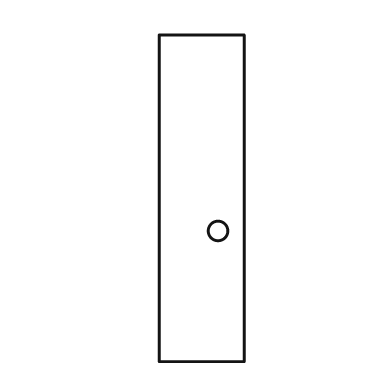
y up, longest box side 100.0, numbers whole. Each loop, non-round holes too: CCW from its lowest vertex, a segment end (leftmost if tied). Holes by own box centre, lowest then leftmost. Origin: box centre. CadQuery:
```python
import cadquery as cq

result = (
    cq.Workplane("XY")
    .moveTo(-13.0, -50.0)
    .lineTo(13.0, -50.0)
    .lineTo(13.0, 50.0)
    .lineTo(-13.0, 50.0)
    .close()
    .moveTo(5.0, -10.0)
    .circle(3.0)
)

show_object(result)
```